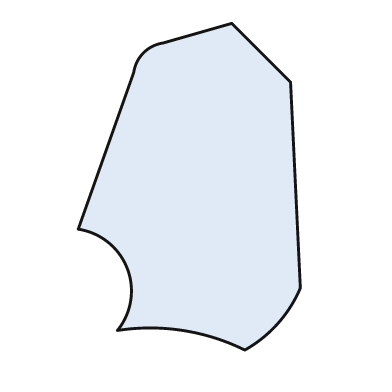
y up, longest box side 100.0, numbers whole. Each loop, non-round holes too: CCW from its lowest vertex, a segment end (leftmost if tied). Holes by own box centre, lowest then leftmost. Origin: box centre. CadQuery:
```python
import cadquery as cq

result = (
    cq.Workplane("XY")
    .moveTo(17.0, -50.0)
    .threePointArc((27.0, -42.0), (34.0, -31.0))
    .lineTo(31.0, 32.0)
    .lineTo(13.0, 50.0)
    .lineTo(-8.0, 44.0)
    .threePointArc((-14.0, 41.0), (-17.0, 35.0))
    .lineTo(-34.0, -13.0)
    .threePointArc((-19.0, -25.0), (-22.0, -44.0))
    .threePointArc((-2.0, -44.0), (17.0, -50.0))
    .close()
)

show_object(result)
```